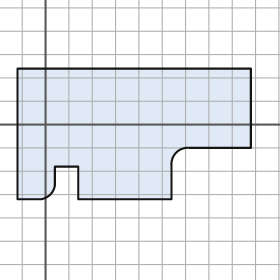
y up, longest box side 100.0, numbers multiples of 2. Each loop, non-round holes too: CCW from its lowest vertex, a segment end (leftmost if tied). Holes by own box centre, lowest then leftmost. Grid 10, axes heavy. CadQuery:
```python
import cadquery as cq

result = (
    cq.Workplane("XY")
    .moveTo(-12.0, -32.0)
    .lineTo(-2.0, -32.0)
    .threePointArc((2.0, -30.0), (4.0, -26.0))
    .lineTo(4.0, -18.0)
    .lineTo(14.0, -18.0)
    .lineTo(14.0, -32.0)
    .lineTo(54.0, -32.0)
    .lineTo(54.0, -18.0)
    .threePointArc((56.0, -12.0), (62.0, -10.0))
    .lineTo(88.0, -10.0)
    .lineTo(88.0, 24.0)
    .lineTo(-12.0, 24.0)
    .close()
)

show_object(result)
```